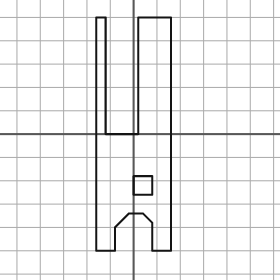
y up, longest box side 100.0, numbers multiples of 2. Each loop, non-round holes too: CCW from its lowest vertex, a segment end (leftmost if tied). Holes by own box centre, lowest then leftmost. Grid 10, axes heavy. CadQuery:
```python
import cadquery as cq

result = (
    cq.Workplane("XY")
    .moveTo(-16.0, -50.0)
    .lineTo(-8.0, -50.0)
    .lineTo(-8.0, -40.0)
    .lineTo(-2.0, -34.0)
    .lineTo(4.0, -34.0)
    .lineTo(8.0, -38.0)
    .lineTo(8.0, -50.0)
    .lineTo(16.0, -50.0)
    .lineTo(16.0, 50.0)
    .lineTo(2.0, 50.0)
    .lineTo(2.0, 0.0)
    .lineTo(-12.0, 0.0)
    .lineTo(-12.0, 50.0)
    .lineTo(-16.0, 50.0)
    .close()
    .moveTo(0.0, -26.0)
    .lineTo(8.0, -26.0)
    .lineTo(8.0, -18.0)
    .lineTo(0.0, -18.0)
    .close()
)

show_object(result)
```